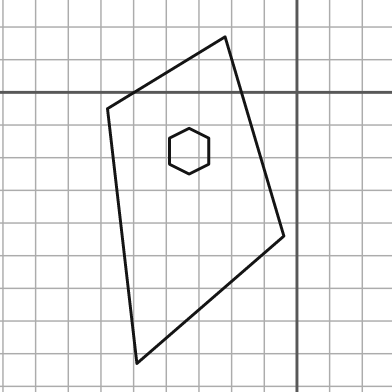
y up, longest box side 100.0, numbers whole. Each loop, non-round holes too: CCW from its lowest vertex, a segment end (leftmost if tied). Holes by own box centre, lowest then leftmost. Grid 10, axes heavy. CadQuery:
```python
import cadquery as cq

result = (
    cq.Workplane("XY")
    .moveTo(-49.0, -83.0)
    .lineTo(-4.0, -44.0)
    .lineTo(-22.0, 17.0)
    .lineTo(-58.0, -5.0)
    .close()
    .moveTo(-33.0, -25.0)
    .lineTo(-27.0, -22.0)
    .lineTo(-27.0, -14.0)
    .lineTo(-33.0, -11.0)
    .lineTo(-39.0, -14.0)
    .lineTo(-39.0, -22.0)
    .close()
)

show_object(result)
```